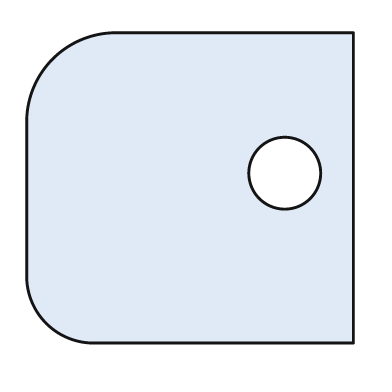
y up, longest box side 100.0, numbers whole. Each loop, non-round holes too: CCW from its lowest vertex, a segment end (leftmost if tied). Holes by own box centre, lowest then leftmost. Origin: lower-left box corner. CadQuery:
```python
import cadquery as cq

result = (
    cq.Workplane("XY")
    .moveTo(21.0, 0.0)
    .lineTo(100.0, 0.0)
    .lineTo(100.0, 95.0)
    .lineTo(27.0, 95.0)
    .threePointArc((8.0, 87.0), (0.0, 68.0))
    .lineTo(0.0, 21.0)
    .threePointArc((6.0, 6.0), (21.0, 0.0))
    .close()
    .moveTo(79.0, 52.0)
    .circle(11.0)
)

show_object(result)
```